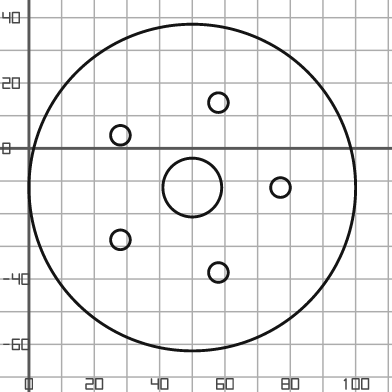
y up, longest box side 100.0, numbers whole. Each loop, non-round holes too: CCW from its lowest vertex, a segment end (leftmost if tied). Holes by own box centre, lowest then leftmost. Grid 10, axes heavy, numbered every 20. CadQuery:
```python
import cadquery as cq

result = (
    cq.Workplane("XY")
    .moveTo(50.0, -12.0)
    .circle(50.0)
    .moveTo(58.0, -38.0)
    .circle(3.0)
    .moveTo(28.0, -28.0)
    .circle(3.0)
    .moveTo(50.0, -12.0)
    .circle(9.0)
    .moveTo(77.0, -12.0)
    .circle(3.0)
    .moveTo(28.0, 4.0)
    .circle(3.0)
    .moveTo(58.0, 14.0)
    .circle(3.0)
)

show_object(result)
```